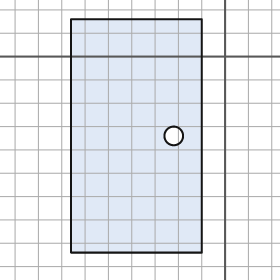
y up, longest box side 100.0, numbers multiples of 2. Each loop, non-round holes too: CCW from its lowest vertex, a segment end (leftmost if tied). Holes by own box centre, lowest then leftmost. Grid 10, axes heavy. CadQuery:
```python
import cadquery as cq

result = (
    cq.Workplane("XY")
    .moveTo(-66.0, -84.0)
    .lineTo(-10.0, -84.0)
    .lineTo(-10.0, 16.0)
    .lineTo(-66.0, 16.0)
    .close()
    .moveTo(-22.0, -34.0)
    .circle(4.0)
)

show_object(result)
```